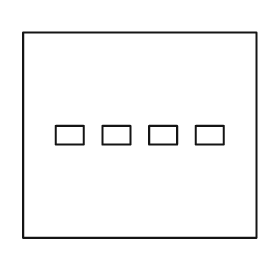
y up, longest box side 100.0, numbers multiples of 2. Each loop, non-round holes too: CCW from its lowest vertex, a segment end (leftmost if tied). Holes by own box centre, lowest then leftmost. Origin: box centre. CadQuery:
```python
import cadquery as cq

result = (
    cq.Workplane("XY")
    .moveTo(-50.0, -44.0)
    .lineTo(50.0, -44.0)
    .lineTo(50.0, 44.0)
    .lineTo(-50.0, 44.0)
    .close()
    .moveTo(-36.0, -4.0)
    .lineTo(-24.0, -4.0)
    .lineTo(-24.0, 4.0)
    .lineTo(-36.0, 4.0)
    .close()
    .moveTo(-16.0, -4.0)
    .lineTo(-4.0, -4.0)
    .lineTo(-4.0, 4.0)
    .lineTo(-16.0, 4.0)
    .close()
    .moveTo(4.0, -4.0)
    .lineTo(16.0, -4.0)
    .lineTo(16.0, 4.0)
    .lineTo(4.0, 4.0)
    .close()
    .moveTo(24.0, -4.0)
    .lineTo(36.0, -4.0)
    .lineTo(36.0, 4.0)
    .lineTo(24.0, 4.0)
    .close()
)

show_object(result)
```